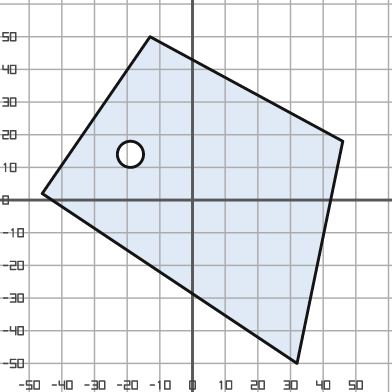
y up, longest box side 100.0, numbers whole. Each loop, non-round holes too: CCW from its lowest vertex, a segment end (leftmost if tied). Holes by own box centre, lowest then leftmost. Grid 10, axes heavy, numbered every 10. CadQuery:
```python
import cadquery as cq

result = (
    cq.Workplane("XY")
    .moveTo(32.0, -50.0)
    .lineTo(46.0, 18.0)
    .lineTo(-13.0, 50.0)
    .lineTo(-46.0, 2.0)
    .close()
    .moveTo(-19.0, 14.0)
    .circle(4.0)
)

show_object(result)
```